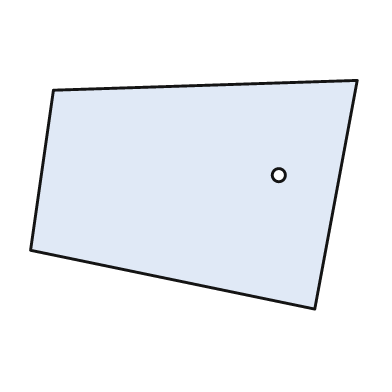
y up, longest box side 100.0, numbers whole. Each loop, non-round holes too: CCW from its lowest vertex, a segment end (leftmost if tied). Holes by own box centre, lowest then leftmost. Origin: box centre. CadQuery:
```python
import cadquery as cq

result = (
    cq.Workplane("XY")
    .moveTo(37.0, -35.0)
    .lineTo(50.0, 35.0)
    .lineTo(-43.0, 32.0)
    .lineTo(-50.0, -17.0)
    .close()
    .moveTo(26.0, 6.0)
    .circle(2.0)
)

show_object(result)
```